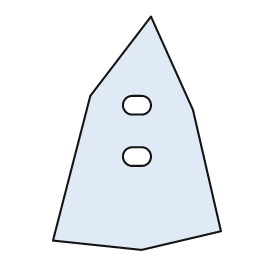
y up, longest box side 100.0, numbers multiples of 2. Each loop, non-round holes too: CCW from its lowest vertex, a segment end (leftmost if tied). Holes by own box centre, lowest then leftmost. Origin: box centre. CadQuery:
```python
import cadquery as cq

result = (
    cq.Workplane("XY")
    .moveTo(2.0, -50.0)
    .lineTo(36.0, -42.0)
    .lineTo(24.0, 10.0)
    .lineTo(6.0, 50.0)
    .lineTo(-20.0, 16.0)
    .lineTo(-36.0, -46.0)
    .close()
    .moveTo(-2.0, -14.0)
    .lineTo(2.0, -14.0)
    .threePointArc((6.0, -10.0), (2.0, -6.0))
    .lineTo(-2.0, -6.0)
    .threePointArc((-6.0, -10.0), (-2.0, -14.0))
    .close()
    .moveTo(-2.0, 8.0)
    .lineTo(2.0, 8.0)
    .threePointArc((6.0, 12.0), (2.0, 16.0))
    .lineTo(-2.0, 16.0)
    .threePointArc((-6.0, 12.0), (-2.0, 8.0))
    .close()
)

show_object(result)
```